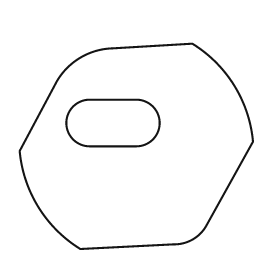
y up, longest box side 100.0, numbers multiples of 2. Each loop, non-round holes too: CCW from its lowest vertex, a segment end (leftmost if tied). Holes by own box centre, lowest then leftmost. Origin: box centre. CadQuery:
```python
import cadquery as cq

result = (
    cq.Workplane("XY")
    .moveTo(-24.0, -44.0)
    .lineTo(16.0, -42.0)
    .threePointArc((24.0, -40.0), (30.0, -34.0))
    .lineTo(50.0, 2.0)
    .threePointArc((42.0, 26.0), (24.0, 44.0))
    .lineTo(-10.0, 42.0)
    .threePointArc((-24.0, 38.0), (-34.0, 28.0))
    .lineTo(-50.0, -2.0)
    .threePointArc((-42.0, -26.0), (-24.0, -44.0))
    .close()
    .moveTo(-20.0, 0.0)
    .lineTo(0.0, 0.0)
    .threePointArc((10.0, 10.0), (0.0, 20.0))
    .lineTo(-20.0, 20.0)
    .threePointArc((-30.0, 10.0), (-20.0, 0.0))
    .close()
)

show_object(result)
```